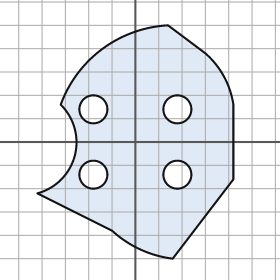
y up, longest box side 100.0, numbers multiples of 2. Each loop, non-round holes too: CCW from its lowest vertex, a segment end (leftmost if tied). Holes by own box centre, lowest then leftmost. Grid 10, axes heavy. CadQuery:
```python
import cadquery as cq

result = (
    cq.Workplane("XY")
    .moveTo(16.0, -50.0)
    .lineTo(42.0, -16.0)
    .lineTo(42.0, 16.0)
    .threePointArc((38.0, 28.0), (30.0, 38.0))
    .lineTo(14.0, 50.0)
    .threePointArc((-14.0, 40.0), (-32.0, 16.0))
    .threePointArc((-26.0, -6.0), (-42.0, -22.0))
    .lineTo(-10.0, -38.0)
    .threePointArc((2.0, -46.0), (16.0, -50.0))
    .close()
    .moveTo(-18.0, -14.0)
    .circle(6.0)
    .moveTo(18.0, -14.0)
    .circle(6.0)
    .moveTo(-18.0, 14.0)
    .circle(6.0)
    .moveTo(18.0, 14.0)
    .circle(6.0)
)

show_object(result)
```